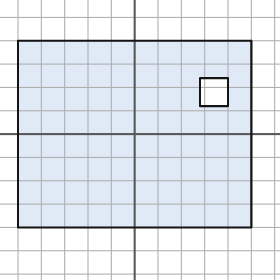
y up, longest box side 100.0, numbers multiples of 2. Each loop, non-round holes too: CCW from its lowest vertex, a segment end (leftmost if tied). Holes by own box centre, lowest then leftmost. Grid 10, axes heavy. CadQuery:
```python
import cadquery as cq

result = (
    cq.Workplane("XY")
    .moveTo(-50.0, -40.0)
    .lineTo(50.0, -40.0)
    .lineTo(50.0, 40.0)
    .lineTo(-50.0, 40.0)
    .close()
    .moveTo(28.0, 12.0)
    .lineTo(40.0, 12.0)
    .lineTo(40.0, 24.0)
    .lineTo(28.0, 24.0)
    .close()
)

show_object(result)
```